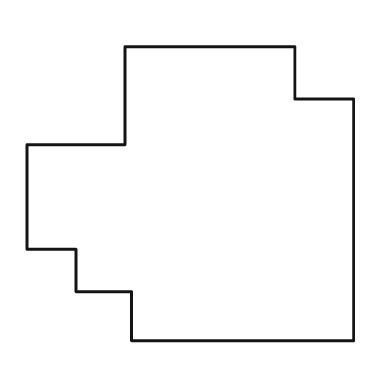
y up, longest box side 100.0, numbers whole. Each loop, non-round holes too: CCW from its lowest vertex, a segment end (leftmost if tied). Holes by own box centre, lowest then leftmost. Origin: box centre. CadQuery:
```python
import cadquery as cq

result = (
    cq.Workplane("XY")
    .moveTo(-18.0, -45.0)
    .lineTo(50.0, -45.0)
    .lineTo(50.0, 29.0)
    .lineTo(32.0, 29.0)
    .lineTo(32.0, 45.0)
    .lineTo(-20.0, 45.0)
    .lineTo(-20.0, 15.0)
    .lineTo(-50.0, 15.0)
    .lineTo(-50.0, -17.0)
    .lineTo(-35.0, -17.0)
    .lineTo(-35.0, -30.0)
    .lineTo(-18.0, -30.0)
    .close()
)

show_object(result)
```